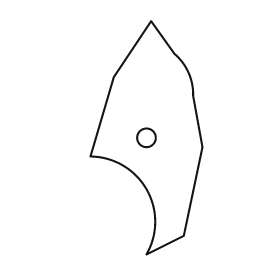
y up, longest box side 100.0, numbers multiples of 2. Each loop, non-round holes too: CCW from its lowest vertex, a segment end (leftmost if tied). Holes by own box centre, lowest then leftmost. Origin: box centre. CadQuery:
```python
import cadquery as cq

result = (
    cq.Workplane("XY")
    .moveTo(0.0, -50.0)
    .lineTo(16.0, -42.0)
    .lineTo(24.0, -4.0)
    .lineTo(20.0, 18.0)
    .threePointArc((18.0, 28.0), (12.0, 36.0))
    .lineTo(2.0, 50.0)
    .lineTo(-14.0, 26.0)
    .lineTo(-24.0, -8.0)
    .threePointArc((0.0, -22.0), (0.0, -50.0))
    .close()
    .moveTo(0.0, 0.0)
    .circle(4.0)
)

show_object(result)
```